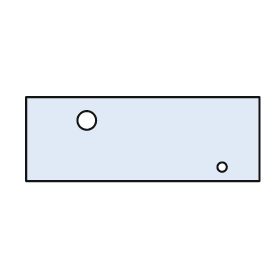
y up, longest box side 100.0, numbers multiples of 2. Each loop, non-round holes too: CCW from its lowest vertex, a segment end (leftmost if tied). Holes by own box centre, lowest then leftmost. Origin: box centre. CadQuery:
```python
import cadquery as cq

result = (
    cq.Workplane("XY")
    .moveTo(-50.0, -18.0)
    .lineTo(50.0, -18.0)
    .lineTo(50.0, 18.0)
    .lineTo(-50.0, 18.0)
    .close()
    .moveTo(34.0, -12.0)
    .circle(2.0)
    .moveTo(-24.0, 8.0)
    .circle(4.0)
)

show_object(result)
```